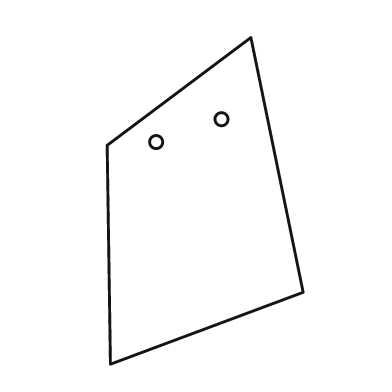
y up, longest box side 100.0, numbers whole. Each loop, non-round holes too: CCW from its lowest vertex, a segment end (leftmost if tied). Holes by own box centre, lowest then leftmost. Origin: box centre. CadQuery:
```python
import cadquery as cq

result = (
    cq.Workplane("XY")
    .moveTo(-29.0, -50.0)
    .lineTo(30.0, -28.0)
    .lineTo(14.0, 50.0)
    .lineTo(-30.0, 17.0)
    .close()
    .moveTo(-15.0, 18.0)
    .circle(2.0)
    .moveTo(5.0, 25.0)
    .circle(2.0)
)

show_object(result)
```